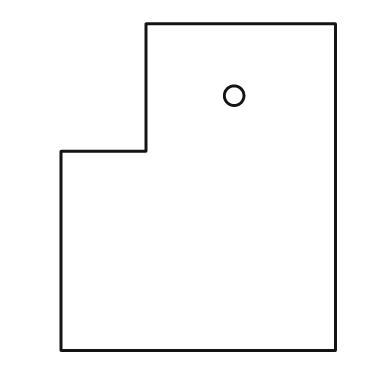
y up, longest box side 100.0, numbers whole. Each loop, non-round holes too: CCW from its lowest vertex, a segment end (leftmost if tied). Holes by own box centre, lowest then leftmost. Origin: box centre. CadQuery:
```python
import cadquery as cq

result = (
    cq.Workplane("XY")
    .moveTo(-42.0, -50.0)
    .lineTo(42.0, -50.0)
    .lineTo(42.0, 50.0)
    .lineTo(-16.0, 50.0)
    .lineTo(-16.0, 11.0)
    .lineTo(-42.0, 11.0)
    .close()
    .moveTo(11.0, 28.0)
    .circle(3.0)
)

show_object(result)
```